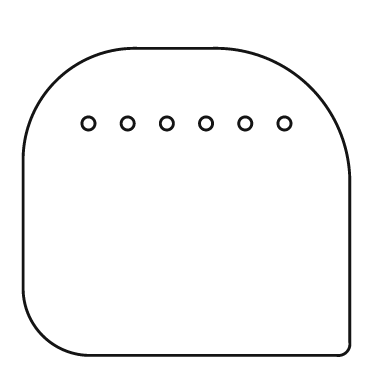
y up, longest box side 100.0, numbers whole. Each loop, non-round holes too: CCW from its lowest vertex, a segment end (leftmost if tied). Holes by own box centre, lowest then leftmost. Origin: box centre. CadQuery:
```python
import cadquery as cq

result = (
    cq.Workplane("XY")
    .moveTo(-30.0, -47.0)
    .lineTo(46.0, -47.0)
    .threePointArc((49.0, -46.0), (50.0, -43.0))
    .lineTo(50.0, 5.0)
    .threePointArc((38.0, 35.0), (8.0, 47.0))
    .lineTo(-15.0, 47.0)
    .threePointArc((-40.0, 37.0), (-50.0, 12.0))
    .lineTo(-50.0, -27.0)
    .threePointArc((-44.0, -41.0), (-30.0, -47.0))
    .close()
    .moveTo(-30.0, 24.0)
    .circle(2.0)
    .moveTo(-18.0, 24.0)
    .circle(2.0)
    .moveTo(-6.0, 24.0)
    .circle(2.0)
    .moveTo(6.0, 24.0)
    .circle(2.0)
    .moveTo(18.0, 24.0)
    .circle(2.0)
    .moveTo(30.0, 24.0)
    .circle(2.0)
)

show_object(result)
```